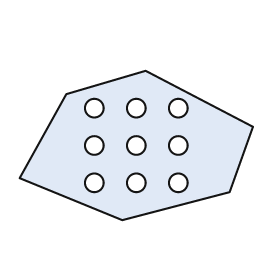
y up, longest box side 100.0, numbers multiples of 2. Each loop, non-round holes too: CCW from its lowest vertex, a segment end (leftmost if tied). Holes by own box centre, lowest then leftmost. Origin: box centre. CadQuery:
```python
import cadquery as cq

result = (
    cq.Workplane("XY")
    .moveTo(-6.0, -32.0)
    .lineTo(40.0, -20.0)
    .lineTo(50.0, 8.0)
    .lineTo(4.0, 32.0)
    .lineTo(-30.0, 22.0)
    .lineTo(-50.0, -14.0)
    .close()
    .moveTo(-18.0, -16.0)
    .circle(4.0)
    .moveTo(0.0, -16.0)
    .circle(4.0)
    .moveTo(18.0, -16.0)
    .circle(4.0)
    .moveTo(-18.0, 0.0)
    .circle(4.0)
    .moveTo(0.0, 0.0)
    .circle(4.0)
    .moveTo(18.0, 0.0)
    .circle(4.0)
    .moveTo(-18.0, 16.0)
    .circle(4.0)
    .moveTo(0.0, 16.0)
    .circle(4.0)
    .moveTo(18.0, 16.0)
    .circle(4.0)
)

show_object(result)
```